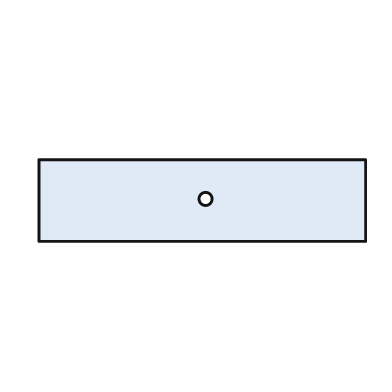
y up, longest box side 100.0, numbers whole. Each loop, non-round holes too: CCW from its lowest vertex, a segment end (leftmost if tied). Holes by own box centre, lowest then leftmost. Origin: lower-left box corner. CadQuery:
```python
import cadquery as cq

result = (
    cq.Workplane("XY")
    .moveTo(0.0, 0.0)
    .lineTo(100.0, 0.0)
    .lineTo(100.0, 25.0)
    .lineTo(0.0, 25.0)
    .close()
    .moveTo(51.0, 13.0)
    .circle(2.0)
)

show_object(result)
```